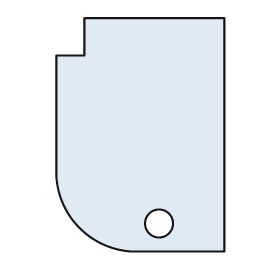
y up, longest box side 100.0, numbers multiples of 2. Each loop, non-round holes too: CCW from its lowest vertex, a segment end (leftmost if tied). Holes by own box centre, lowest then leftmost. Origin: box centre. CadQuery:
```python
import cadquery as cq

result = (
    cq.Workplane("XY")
    .moveTo(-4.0, -50.0)
    .lineTo(36.0, -50.0)
    .lineTo(36.0, 50.0)
    .lineTo(-24.0, 50.0)
    .lineTo(-24.0, 34.0)
    .lineTo(-36.0, 34.0)
    .lineTo(-36.0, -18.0)
    .threePointArc((-26.0, -40.0), (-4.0, -50.0))
    .close()
    .moveTo(8.0, -38.0)
    .circle(6.0)
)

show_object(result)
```